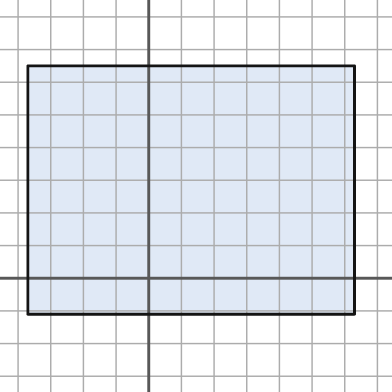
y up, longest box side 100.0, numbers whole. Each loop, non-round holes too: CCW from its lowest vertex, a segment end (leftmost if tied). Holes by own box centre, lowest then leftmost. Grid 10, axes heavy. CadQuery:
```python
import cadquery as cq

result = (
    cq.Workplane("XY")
    .moveTo(-37.0, -11.0)
    .lineTo(63.0, -11.0)
    .lineTo(63.0, 65.0)
    .lineTo(-37.0, 65.0)
    .close()
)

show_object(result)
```